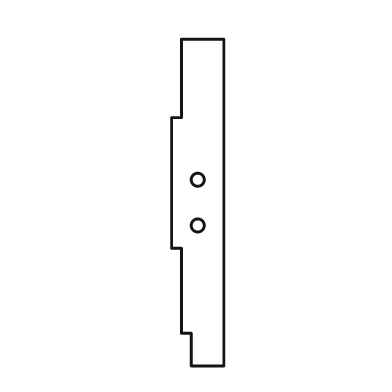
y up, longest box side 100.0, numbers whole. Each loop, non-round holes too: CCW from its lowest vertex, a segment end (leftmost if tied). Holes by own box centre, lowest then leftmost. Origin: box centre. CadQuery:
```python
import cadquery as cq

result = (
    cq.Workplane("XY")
    .moveTo(-2.0, -50.0)
    .lineTo(8.0, -50.0)
    .lineTo(8.0, 50.0)
    .lineTo(-5.0, 50.0)
    .lineTo(-5.0, 26.0)
    .lineTo(-8.0, 26.0)
    .lineTo(-8.0, -14.0)
    .lineTo(-5.0, -14.0)
    .lineTo(-5.0, -40.0)
    .lineTo(-2.0, -40.0)
    .close()
    .moveTo(0.0, -7.0)
    .circle(2.0)
    .moveTo(0.0, 7.0)
    .circle(2.0)
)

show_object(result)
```